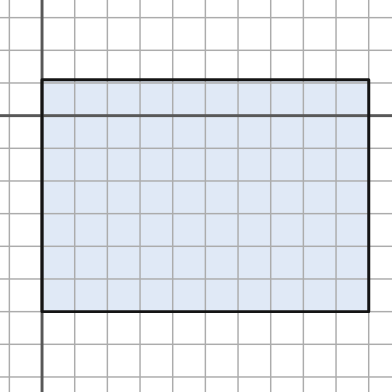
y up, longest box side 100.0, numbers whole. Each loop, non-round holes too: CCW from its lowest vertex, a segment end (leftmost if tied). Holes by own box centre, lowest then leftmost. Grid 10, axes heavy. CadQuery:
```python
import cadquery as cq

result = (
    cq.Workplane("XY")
    .moveTo(0.0, -60.0)
    .lineTo(100.0, -60.0)
    .lineTo(100.0, 11.0)
    .lineTo(0.0, 11.0)
    .close()
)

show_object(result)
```